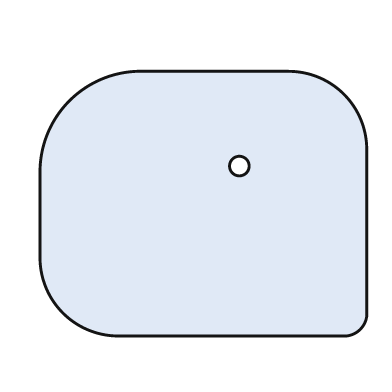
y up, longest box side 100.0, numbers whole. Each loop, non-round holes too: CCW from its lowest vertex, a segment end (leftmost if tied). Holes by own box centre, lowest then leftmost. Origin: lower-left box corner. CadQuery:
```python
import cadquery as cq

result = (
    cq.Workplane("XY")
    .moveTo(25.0, 0.0)
    .lineTo(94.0, 0.0)
    .threePointArc((98.0, 2.0), (100.0, 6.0))
    .lineTo(100.0, 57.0)
    .threePointArc((93.0, 74.0), (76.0, 81.0))
    .lineTo(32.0, 81.0)
    .threePointArc((9.0, 72.0), (0.0, 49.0))
    .lineTo(0.0, 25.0)
    .threePointArc((7.0, 7.0), (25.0, 0.0))
    .close()
    .moveTo(61.0, 52.0)
    .circle(3.0)
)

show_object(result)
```